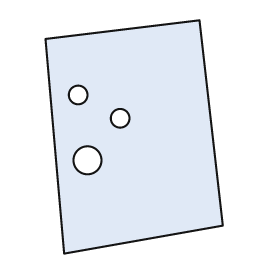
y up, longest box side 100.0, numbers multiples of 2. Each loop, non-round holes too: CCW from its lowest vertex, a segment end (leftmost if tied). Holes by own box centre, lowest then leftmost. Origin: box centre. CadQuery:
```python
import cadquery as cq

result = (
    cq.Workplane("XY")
    .moveTo(-30.0, -50.0)
    .lineTo(38.0, -38.0)
    .lineTo(28.0, 50.0)
    .lineTo(-38.0, 42.0)
    .close()
    .moveTo(-20.0, -10.0)
    .circle(6.0)
    .moveTo(-6.0, 8.0)
    .circle(4.0)
    .moveTo(-24.0, 18.0)
    .circle(4.0)
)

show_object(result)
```